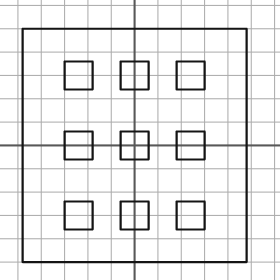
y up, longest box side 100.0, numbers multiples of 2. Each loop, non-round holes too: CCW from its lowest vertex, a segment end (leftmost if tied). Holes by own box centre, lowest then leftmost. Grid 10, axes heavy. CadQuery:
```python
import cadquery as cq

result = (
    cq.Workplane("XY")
    .moveTo(-48.0, -50.0)
    .lineTo(48.0, -50.0)
    .lineTo(48.0, 50.0)
    .lineTo(-48.0, 50.0)
    .close()
    .moveTo(-30.0, -36.0)
    .lineTo(-18.0, -36.0)
    .lineTo(-18.0, -24.0)
    .lineTo(-30.0, -24.0)
    .close()
    .moveTo(-6.0, -36.0)
    .lineTo(6.0, -36.0)
    .lineTo(6.0, -24.0)
    .lineTo(-6.0, -24.0)
    .close()
    .moveTo(18.0, -36.0)
    .lineTo(30.0, -36.0)
    .lineTo(30.0, -24.0)
    .lineTo(18.0, -24.0)
    .close()
    .moveTo(-30.0, -6.0)
    .lineTo(-18.0, -6.0)
    .lineTo(-18.0, 6.0)
    .lineTo(-30.0, 6.0)
    .close()
    .moveTo(-6.0, -6.0)
    .lineTo(6.0, -6.0)
    .lineTo(6.0, 6.0)
    .lineTo(-6.0, 6.0)
    .close()
    .moveTo(18.0, -6.0)
    .lineTo(30.0, -6.0)
    .lineTo(30.0, 6.0)
    .lineTo(18.0, 6.0)
    .close()
    .moveTo(-30.0, 24.0)
    .lineTo(-18.0, 24.0)
    .lineTo(-18.0, 36.0)
    .lineTo(-30.0, 36.0)
    .close()
    .moveTo(-6.0, 24.0)
    .lineTo(6.0, 24.0)
    .lineTo(6.0, 36.0)
    .lineTo(-6.0, 36.0)
    .close()
    .moveTo(18.0, 24.0)
    .lineTo(30.0, 24.0)
    .lineTo(30.0, 36.0)
    .lineTo(18.0, 36.0)
    .close()
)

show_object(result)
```